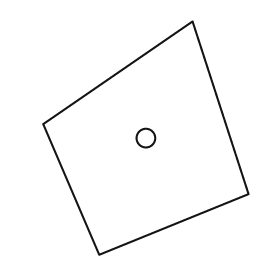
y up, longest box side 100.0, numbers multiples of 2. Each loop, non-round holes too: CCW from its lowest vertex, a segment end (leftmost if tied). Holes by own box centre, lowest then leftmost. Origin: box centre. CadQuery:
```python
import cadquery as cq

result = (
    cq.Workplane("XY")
    .moveTo(-20.0, -50.0)
    .lineTo(44.0, -24.0)
    .lineTo(20.0, 50.0)
    .lineTo(-44.0, 6.0)
    .close()
    .moveTo(0.0, 0.0)
    .circle(4.0)
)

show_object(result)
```